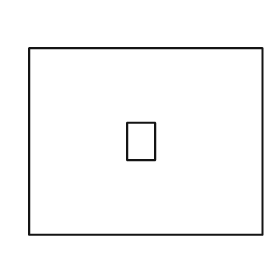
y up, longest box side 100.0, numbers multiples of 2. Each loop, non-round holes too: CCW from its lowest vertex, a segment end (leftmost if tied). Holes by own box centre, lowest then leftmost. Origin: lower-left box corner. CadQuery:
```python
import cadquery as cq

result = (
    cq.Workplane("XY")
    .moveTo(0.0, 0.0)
    .lineTo(100.0, 0.0)
    .lineTo(100.0, 80.0)
    .lineTo(0.0, 80.0)
    .close()
    .moveTo(42.0, 32.0)
    .lineTo(54.0, 32.0)
    .lineTo(54.0, 48.0)
    .lineTo(42.0, 48.0)
    .close()
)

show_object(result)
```